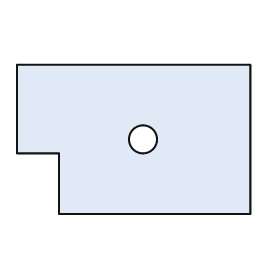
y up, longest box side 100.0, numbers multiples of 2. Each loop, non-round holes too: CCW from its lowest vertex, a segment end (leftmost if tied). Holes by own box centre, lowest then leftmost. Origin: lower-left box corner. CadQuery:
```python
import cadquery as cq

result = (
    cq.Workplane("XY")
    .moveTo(18.0, 0.0)
    .lineTo(100.0, 0.0)
    .lineTo(100.0, 64.0)
    .lineTo(0.0, 64.0)
    .lineTo(0.0, 26.0)
    .lineTo(18.0, 26.0)
    .close()
    .moveTo(54.0, 32.0)
    .circle(6.0)
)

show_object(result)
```